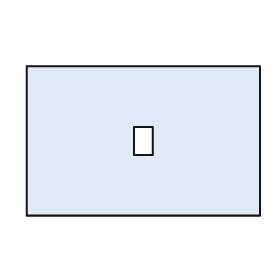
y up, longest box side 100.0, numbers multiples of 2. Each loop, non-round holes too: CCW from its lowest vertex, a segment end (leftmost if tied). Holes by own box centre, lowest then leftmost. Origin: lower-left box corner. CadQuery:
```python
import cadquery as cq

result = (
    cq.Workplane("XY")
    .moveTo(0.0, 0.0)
    .lineTo(100.0, 0.0)
    .lineTo(100.0, 64.0)
    .lineTo(0.0, 64.0)
    .close()
    .moveTo(46.0, 26.0)
    .lineTo(54.0, 26.0)
    .lineTo(54.0, 38.0)
    .lineTo(46.0, 38.0)
    .close()
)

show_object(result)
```